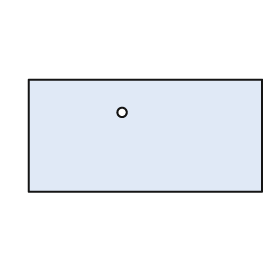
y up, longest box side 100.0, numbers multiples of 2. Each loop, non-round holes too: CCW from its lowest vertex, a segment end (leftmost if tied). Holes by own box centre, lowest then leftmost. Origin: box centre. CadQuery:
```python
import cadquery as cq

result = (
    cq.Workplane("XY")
    .moveTo(-50.0, -24.0)
    .lineTo(50.0, -24.0)
    .lineTo(50.0, 24.0)
    .lineTo(-50.0, 24.0)
    .close()
    .moveTo(-10.0, 10.0)
    .circle(2.0)
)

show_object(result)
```